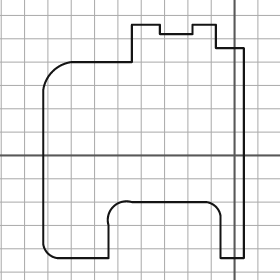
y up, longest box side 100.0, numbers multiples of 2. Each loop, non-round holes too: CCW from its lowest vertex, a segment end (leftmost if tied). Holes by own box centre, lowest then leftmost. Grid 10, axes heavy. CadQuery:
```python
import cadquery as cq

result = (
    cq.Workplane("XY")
    .moveTo(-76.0, -44.0)
    .lineTo(-54.0, -44.0)
    .lineTo(-54.0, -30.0)
    .threePointArc((-52.0, -22.0), (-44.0, -20.0))
    .lineTo(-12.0, -20.0)
    .threePointArc((-8.0, -22.0), (-6.0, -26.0))
    .lineTo(-6.0, -44.0)
    .lineTo(4.0, -44.0)
    .lineTo(4.0, 46.0)
    .lineTo(-8.0, 46.0)
    .lineTo(-8.0, 56.0)
    .lineTo(-18.0, 56.0)
    .lineTo(-18.0, 52.0)
    .lineTo(-32.0, 52.0)
    .lineTo(-32.0, 56.0)
    .lineTo(-44.0, 56.0)
    .lineTo(-44.0, 40.0)
    .lineTo(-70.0, 40.0)
    .threePointArc((-78.0, 36.0), (-82.0, 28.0))
    .lineTo(-82.0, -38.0)
    .threePointArc((-80.0, -42.0), (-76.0, -44.0))
    .close()
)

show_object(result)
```